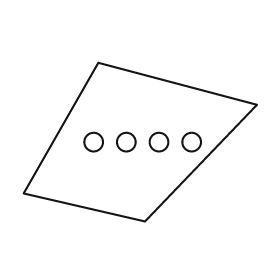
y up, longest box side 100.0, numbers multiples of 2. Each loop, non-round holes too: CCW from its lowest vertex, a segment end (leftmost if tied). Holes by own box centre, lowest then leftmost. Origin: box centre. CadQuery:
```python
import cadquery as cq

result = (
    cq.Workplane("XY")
    .moveTo(2.0, -34.0)
    .lineTo(50.0, 16.0)
    .lineTo(-18.0, 34.0)
    .lineTo(-50.0, -22.0)
    .close()
    .moveTo(-20.0, 0.0)
    .circle(4.0)
    .moveTo(-6.0, 0.0)
    .circle(4.0)
    .moveTo(8.0, 0.0)
    .circle(4.0)
    .moveTo(22.0, 0.0)
    .circle(4.0)
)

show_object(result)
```